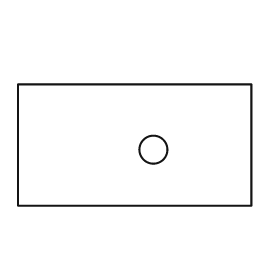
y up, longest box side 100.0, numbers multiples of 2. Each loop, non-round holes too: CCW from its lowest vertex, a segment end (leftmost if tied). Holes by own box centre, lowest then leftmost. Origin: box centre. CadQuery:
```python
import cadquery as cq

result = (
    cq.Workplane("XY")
    .moveTo(-50.0, -26.0)
    .lineTo(50.0, -26.0)
    .lineTo(50.0, 26.0)
    .lineTo(-50.0, 26.0)
    .close()
    .moveTo(8.0, -2.0)
    .circle(6.0)
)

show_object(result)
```